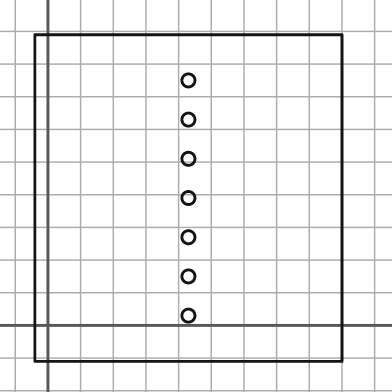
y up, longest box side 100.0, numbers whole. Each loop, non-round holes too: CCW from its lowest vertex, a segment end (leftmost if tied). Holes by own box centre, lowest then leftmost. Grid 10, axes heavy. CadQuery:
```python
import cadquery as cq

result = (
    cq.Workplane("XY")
    .moveTo(-4.0, -11.0)
    .lineTo(90.0, -11.0)
    .lineTo(90.0, 89.0)
    .lineTo(-4.0, 89.0)
    .close()
    .moveTo(43.0, 3.0)
    .circle(2.0)
    .moveTo(43.0, 15.0)
    .circle(2.0)
    .moveTo(43.0, 27.0)
    .circle(2.0)
    .moveTo(43.0, 39.0)
    .circle(2.0)
    .moveTo(43.0, 51.0)
    .circle(2.0)
    .moveTo(43.0, 63.0)
    .circle(2.0)
    .moveTo(43.0, 75.0)
    .circle(2.0)
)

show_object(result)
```